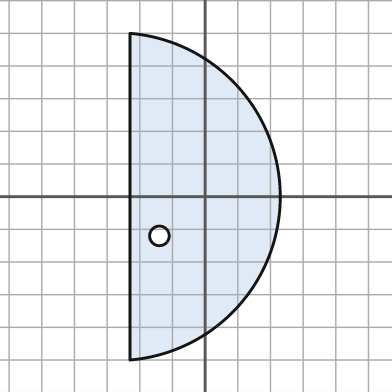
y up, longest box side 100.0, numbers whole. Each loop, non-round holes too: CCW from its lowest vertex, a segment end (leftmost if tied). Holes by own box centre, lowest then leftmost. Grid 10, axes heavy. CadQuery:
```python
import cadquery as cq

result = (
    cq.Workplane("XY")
    .moveTo(-23.0, -50.0)
    .threePointArc((23.0, 0.0), (-23.0, 50.0))
    .close()
    .moveTo(-14.0, -12.0)
    .circle(3.0)
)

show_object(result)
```